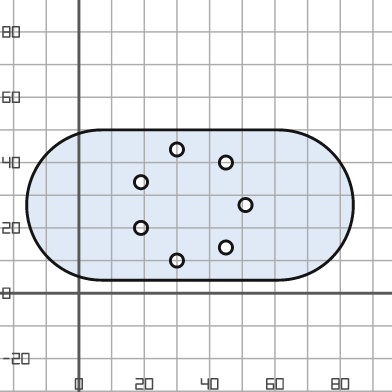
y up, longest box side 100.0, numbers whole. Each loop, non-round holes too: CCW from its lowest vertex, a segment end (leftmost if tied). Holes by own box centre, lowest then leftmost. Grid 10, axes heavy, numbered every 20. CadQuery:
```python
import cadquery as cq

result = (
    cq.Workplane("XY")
    .moveTo(7.0, 4.0)
    .lineTo(61.0, 4.0)
    .threePointArc((84.0, 27.0), (61.0, 50.0))
    .lineTo(7.0, 50.0)
    .threePointArc((-16.0, 27.0), (7.0, 4.0))
    .close()
    .moveTo(30.0, 10.0)
    .circle(2.0)
    .moveTo(45.0, 14.0)
    .circle(2.0)
    .moveTo(19.0, 20.0)
    .circle(2.0)
    .moveTo(51.0, 27.0)
    .circle(2.0)
    .moveTo(19.0, 34.0)
    .circle(2.0)
    .moveTo(45.0, 40.0)
    .circle(2.0)
    .moveTo(30.0, 44.0)
    .circle(2.0)
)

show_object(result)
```